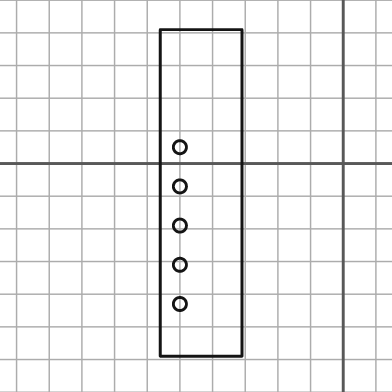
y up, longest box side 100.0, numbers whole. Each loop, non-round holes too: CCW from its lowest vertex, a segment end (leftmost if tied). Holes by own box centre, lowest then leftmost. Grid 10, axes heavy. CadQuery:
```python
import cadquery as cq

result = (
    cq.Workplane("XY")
    .moveTo(-56.0, -59.0)
    .lineTo(-31.0, -59.0)
    .lineTo(-31.0, 41.0)
    .lineTo(-56.0, 41.0)
    .close()
    .moveTo(-50.0, -43.0)
    .circle(2.0)
    .moveTo(-50.0, -31.0)
    .circle(2.0)
    .moveTo(-50.0, -19.0)
    .circle(2.0)
    .moveTo(-50.0, -7.0)
    .circle(2.0)
    .moveTo(-50.0, 5.0)
    .circle(2.0)
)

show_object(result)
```